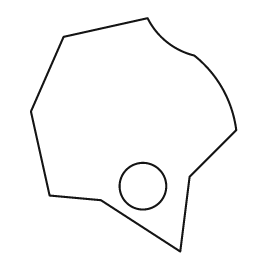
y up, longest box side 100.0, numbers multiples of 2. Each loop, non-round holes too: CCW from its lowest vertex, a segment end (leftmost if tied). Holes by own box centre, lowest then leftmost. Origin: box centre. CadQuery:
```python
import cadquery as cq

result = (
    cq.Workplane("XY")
    .moveTo(20.0, -50.0)
    .lineTo(24.0, -18.0)
    .lineTo(44.0, 2.0)
    .threePointArc((38.0, 20.0), (26.0, 34.0))
    .threePointArc((14.0, 40.0), (6.0, 50.0))
    .lineTo(-30.0, 42.0)
    .lineTo(-44.0, 10.0)
    .lineTo(-36.0, -26.0)
    .lineTo(-14.0, -28.0)
    .close()
    .moveTo(4.0, -22.0)
    .circle(10.0)
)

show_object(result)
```